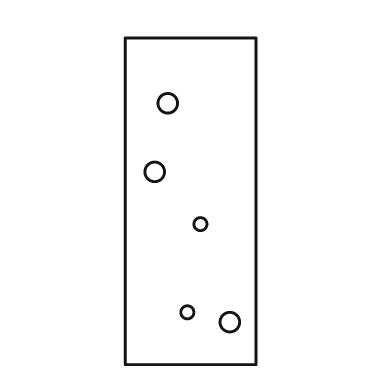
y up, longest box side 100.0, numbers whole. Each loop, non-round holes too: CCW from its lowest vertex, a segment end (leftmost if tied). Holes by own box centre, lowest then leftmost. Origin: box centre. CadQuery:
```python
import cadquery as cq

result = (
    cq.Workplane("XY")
    .moveTo(-20.0, -50.0)
    .lineTo(20.0, -50.0)
    .lineTo(20.0, 50.0)
    .lineTo(-20.0, 50.0)
    .close()
    .moveTo(12.0, -37.0)
    .circle(3.0)
    .moveTo(-1.0, -34.0)
    .circle(2.0)
    .moveTo(3.0, -7.0)
    .circle(2.0)
    .moveTo(-11.0, 9.0)
    .circle(3.0)
    .moveTo(-7.0, 30.0)
    .circle(3.0)
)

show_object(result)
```